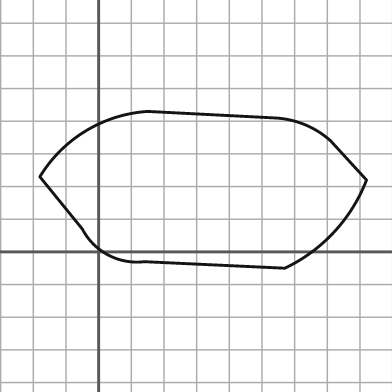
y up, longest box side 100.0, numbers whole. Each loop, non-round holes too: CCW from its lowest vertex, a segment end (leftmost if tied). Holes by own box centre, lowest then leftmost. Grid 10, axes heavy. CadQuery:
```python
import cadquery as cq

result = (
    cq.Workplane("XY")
    .moveTo(57.0, -5.0)
    .threePointArc((72.0, 6.0), (82.0, 22.0))
    .lineTo(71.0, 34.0)
    .threePointArc((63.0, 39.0), (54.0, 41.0))
    .lineTo(15.0, 43.0)
    .threePointArc((-4.0, 37.0), (-18.0, 23.0))
    .lineTo(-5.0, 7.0)
    .threePointArc((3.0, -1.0), (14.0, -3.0))
    .close()
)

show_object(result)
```